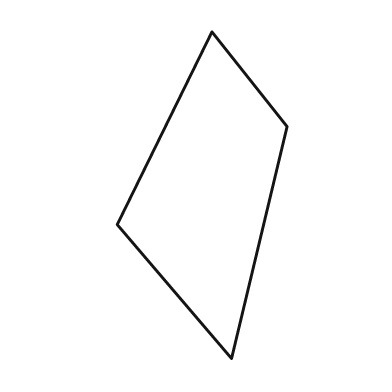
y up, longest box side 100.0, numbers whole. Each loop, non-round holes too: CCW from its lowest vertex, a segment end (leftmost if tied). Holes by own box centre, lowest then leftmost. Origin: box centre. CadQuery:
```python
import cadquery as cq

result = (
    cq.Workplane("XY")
    .moveTo(9.0, -50.0)
    .lineTo(26.0, 21.0)
    .lineTo(3.0, 50.0)
    .lineTo(-26.0, -9.0)
    .close()
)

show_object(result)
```